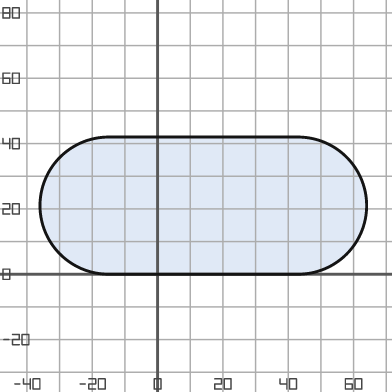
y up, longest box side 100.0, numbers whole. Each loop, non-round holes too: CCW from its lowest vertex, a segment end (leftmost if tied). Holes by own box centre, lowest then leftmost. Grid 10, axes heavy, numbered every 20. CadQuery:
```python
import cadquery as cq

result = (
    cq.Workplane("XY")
    .moveTo(-15.0, 0.0)
    .lineTo(43.0, 0.0)
    .threePointArc((64.0, 21.0), (43.0, 42.0))
    .lineTo(-15.0, 42.0)
    .threePointArc((-36.0, 21.0), (-15.0, 0.0))
    .close()
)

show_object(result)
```